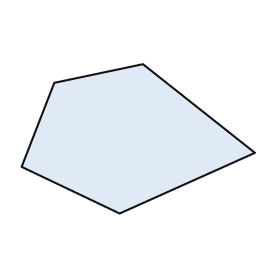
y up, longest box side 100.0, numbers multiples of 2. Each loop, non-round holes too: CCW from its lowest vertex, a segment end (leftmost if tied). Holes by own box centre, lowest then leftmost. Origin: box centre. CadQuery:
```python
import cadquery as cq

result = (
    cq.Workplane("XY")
    .moveTo(-8.0, -32.0)
    .lineTo(50.0, -6.0)
    .lineTo(2.0, 32.0)
    .lineTo(-36.0, 24.0)
    .lineTo(-50.0, -12.0)
    .close()
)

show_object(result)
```